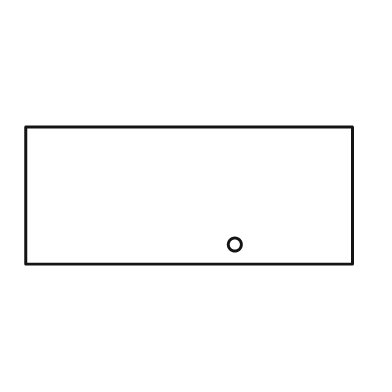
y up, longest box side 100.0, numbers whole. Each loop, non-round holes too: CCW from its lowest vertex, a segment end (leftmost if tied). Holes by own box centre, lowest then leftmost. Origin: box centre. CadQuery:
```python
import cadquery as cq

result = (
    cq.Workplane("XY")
    .moveTo(-50.0, -21.0)
    .lineTo(50.0, -21.0)
    .lineTo(50.0, 21.0)
    .lineTo(-50.0, 21.0)
    .close()
    .moveTo(14.0, -15.0)
    .circle(2.0)
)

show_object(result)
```